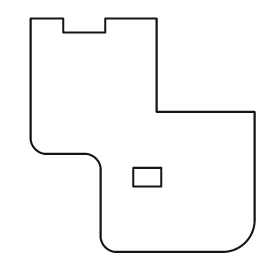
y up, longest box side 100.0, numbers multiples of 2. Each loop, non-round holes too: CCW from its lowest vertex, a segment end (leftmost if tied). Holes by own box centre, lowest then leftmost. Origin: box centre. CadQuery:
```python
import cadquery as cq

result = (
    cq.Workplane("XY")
    .moveTo(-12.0, -50.0)
    .lineTo(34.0, -50.0)
    .threePointArc((44.0, -46.0), (48.0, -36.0))
    .lineTo(48.0, 10.0)
    .lineTo(6.0, 10.0)
    .lineTo(6.0, 50.0)
    .lineTo(-16.0, 50.0)
    .lineTo(-16.0, 44.0)
    .lineTo(-34.0, 44.0)
    .lineTo(-34.0, 50.0)
    .lineTo(-48.0, 50.0)
    .lineTo(-48.0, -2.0)
    .threePointArc((-46.0, -6.0), (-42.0, -8.0))
    .lineTo(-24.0, -8.0)
    .threePointArc((-20.0, -10.0), (-18.0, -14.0))
    .lineTo(-18.0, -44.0)
    .threePointArc((-16.0, -48.0), (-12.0, -50.0))
    .close()
    .moveTo(-4.0, -22.0)
    .lineTo(8.0, -22.0)
    .lineTo(8.0, -14.0)
    .lineTo(-4.0, -14.0)
    .close()
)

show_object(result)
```